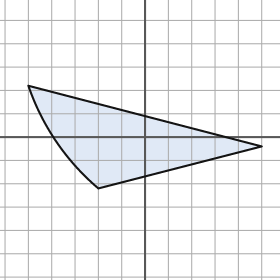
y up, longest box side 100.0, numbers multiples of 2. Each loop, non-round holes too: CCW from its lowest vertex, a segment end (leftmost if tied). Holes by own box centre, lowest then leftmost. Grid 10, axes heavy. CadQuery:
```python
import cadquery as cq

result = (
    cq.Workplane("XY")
    .moveTo(-20.0, -22.0)
    .lineTo(50.0, -4.0)
    .lineTo(-50.0, 22.0)
    .threePointArc((-38.0, -2.0), (-20.0, -22.0))
    .close()
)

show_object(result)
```